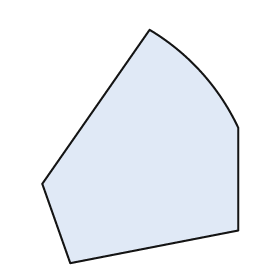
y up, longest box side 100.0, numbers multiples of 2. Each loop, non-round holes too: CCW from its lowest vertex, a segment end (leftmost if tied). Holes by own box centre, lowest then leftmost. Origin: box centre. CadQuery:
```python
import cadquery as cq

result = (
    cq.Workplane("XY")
    .moveTo(-30.0, -50.0)
    .lineTo(42.0, -36.0)
    .lineTo(42.0, 8.0)
    .threePointArc((26.0, 32.0), (4.0, 50.0))
    .lineTo(-42.0, -16.0)
    .close()
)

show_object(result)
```